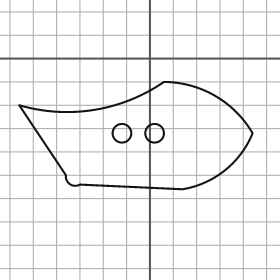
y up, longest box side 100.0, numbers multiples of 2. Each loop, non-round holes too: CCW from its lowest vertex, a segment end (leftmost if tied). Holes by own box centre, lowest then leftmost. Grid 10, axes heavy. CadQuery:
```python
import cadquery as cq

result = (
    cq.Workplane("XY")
    .moveTo(14.0, -56.0)
    .threePointArc((32.0, -48.0), (44.0, -32.0))
    .threePointArc((28.0, -16.0), (6.0, -10.0))
    .threePointArc((-24.0, -22.0), (-56.0, -20.0))
    .lineTo(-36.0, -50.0)
    .threePointArc((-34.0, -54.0), (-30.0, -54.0))
    .close()
    .moveTo(-12.0, -32.0)
    .circle(4.0)
    .moveTo(2.0, -32.0)
    .circle(4.0)
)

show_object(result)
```